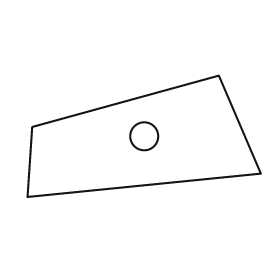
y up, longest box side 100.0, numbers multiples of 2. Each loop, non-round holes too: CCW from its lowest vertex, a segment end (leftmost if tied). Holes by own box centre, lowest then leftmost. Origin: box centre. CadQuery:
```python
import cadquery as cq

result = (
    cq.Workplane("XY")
    .moveTo(-50.0, -26.0)
    .lineTo(50.0, -16.0)
    .lineTo(32.0, 26.0)
    .lineTo(-48.0, 4.0)
    .close()
    .moveTo(0.0, 0.0)
    .circle(6.0)
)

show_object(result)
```